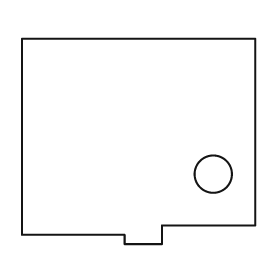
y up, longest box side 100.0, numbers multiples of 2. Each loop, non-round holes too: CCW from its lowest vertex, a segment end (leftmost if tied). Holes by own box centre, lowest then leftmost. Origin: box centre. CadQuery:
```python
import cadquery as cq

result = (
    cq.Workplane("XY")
    .moveTo(-6.0, -44.0)
    .lineTo(10.0, -44.0)
    .lineTo(10.0, -36.0)
    .lineTo(50.0, -36.0)
    .lineTo(50.0, 44.0)
    .lineTo(-50.0, 44.0)
    .lineTo(-50.0, -40.0)
    .lineTo(-6.0, -40.0)
    .close()
    .moveTo(32.0, -14.0)
    .circle(8.0)
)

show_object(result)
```